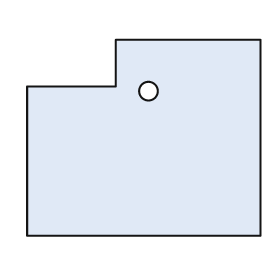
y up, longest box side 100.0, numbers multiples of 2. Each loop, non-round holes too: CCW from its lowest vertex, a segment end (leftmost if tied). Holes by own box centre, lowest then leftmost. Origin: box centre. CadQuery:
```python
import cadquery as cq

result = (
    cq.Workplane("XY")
    .moveTo(-50.0, -42.0)
    .lineTo(50.0, -42.0)
    .lineTo(50.0, 42.0)
    .lineTo(-12.0, 42.0)
    .lineTo(-12.0, 22.0)
    .lineTo(-50.0, 22.0)
    .close()
    .moveTo(2.0, 20.0)
    .circle(4.0)
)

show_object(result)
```